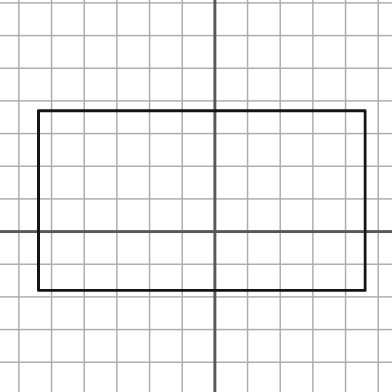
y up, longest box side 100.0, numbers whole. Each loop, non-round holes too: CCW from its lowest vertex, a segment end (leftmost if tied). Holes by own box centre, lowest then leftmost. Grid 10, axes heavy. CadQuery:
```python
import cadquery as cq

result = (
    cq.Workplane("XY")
    .moveTo(-54.0, -18.0)
    .lineTo(46.0, -18.0)
    .lineTo(46.0, 37.0)
    .lineTo(-54.0, 37.0)
    .close()
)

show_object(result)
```